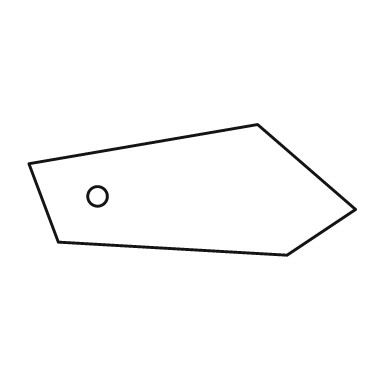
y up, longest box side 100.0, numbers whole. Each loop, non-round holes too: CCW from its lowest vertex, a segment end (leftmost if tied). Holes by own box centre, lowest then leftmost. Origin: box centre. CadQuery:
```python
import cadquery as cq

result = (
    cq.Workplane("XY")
    .moveTo(29.0, -20.0)
    .lineTo(50.0, -6.0)
    .lineTo(20.0, 20.0)
    .lineTo(-50.0, 8.0)
    .lineTo(-41.0, -16.0)
    .close()
    .moveTo(-29.0, -2.0)
    .circle(3.0)
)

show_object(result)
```